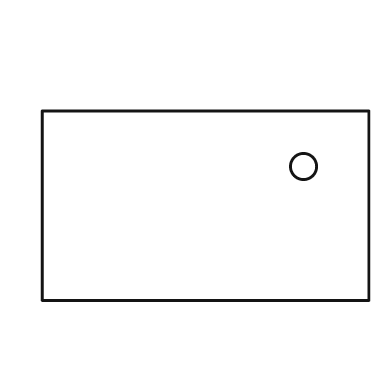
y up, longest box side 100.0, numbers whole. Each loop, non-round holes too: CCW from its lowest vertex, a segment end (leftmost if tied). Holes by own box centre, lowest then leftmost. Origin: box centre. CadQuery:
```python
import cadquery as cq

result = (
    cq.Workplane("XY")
    .moveTo(-50.0, -29.0)
    .lineTo(50.0, -29.0)
    .lineTo(50.0, 29.0)
    .lineTo(-50.0, 29.0)
    .close()
    .moveTo(30.0, 12.0)
    .circle(4.0)
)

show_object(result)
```